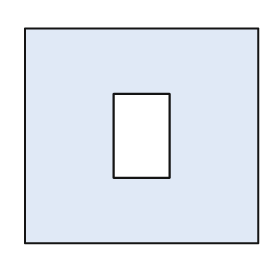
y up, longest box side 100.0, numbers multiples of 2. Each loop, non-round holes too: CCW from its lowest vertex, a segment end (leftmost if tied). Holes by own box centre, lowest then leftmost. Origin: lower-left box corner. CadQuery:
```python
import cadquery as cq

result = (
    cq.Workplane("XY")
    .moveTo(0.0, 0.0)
    .lineTo(100.0, 0.0)
    .lineTo(100.0, 92.0)
    .lineTo(0.0, 92.0)
    .close()
    .moveTo(38.0, 28.0)
    .lineTo(62.0, 28.0)
    .lineTo(62.0, 64.0)
    .lineTo(38.0, 64.0)
    .close()
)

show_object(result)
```